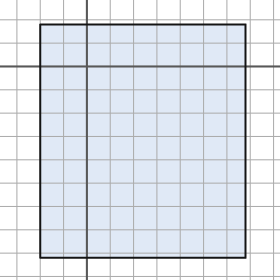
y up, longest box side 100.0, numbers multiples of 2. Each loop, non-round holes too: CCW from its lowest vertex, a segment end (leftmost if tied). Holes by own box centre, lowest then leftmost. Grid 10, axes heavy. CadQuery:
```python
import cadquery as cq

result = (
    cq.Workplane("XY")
    .moveTo(-20.0, -82.0)
    .lineTo(68.0, -82.0)
    .lineTo(68.0, 18.0)
    .lineTo(-20.0, 18.0)
    .close()
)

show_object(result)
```